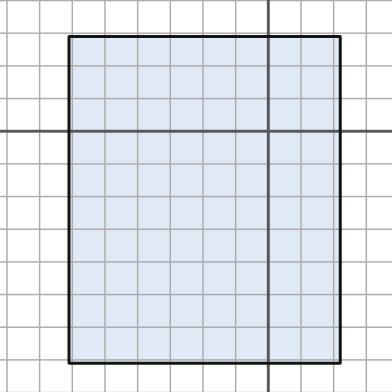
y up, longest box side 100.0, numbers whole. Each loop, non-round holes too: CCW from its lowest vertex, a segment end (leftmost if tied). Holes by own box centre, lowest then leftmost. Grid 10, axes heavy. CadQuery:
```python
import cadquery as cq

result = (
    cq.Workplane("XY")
    .moveTo(-61.0, -71.0)
    .lineTo(22.0, -71.0)
    .lineTo(22.0, 29.0)
    .lineTo(-61.0, 29.0)
    .close()
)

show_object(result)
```